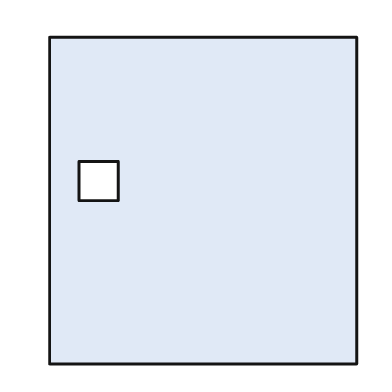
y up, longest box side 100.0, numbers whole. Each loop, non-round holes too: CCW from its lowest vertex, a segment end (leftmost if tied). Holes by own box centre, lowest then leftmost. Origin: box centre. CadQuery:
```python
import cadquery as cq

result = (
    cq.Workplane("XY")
    .moveTo(-47.0, -50.0)
    .lineTo(47.0, -50.0)
    .lineTo(47.0, 50.0)
    .lineTo(-47.0, 50.0)
    .close()
    .moveTo(-38.0, 0.0)
    .lineTo(-26.0, 0.0)
    .lineTo(-26.0, 12.0)
    .lineTo(-38.0, 12.0)
    .close()
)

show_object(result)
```